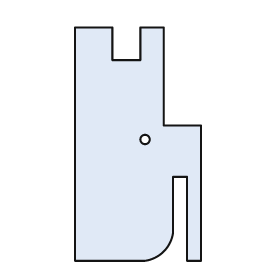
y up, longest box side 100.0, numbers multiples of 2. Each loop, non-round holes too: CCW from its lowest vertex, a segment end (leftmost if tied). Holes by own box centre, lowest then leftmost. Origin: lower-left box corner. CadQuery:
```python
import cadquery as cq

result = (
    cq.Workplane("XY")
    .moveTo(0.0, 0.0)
    .lineTo(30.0, 0.0)
    .threePointArc((38.0, 4.0), (42.0, 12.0))
    .lineTo(42.0, 36.0)
    .lineTo(48.0, 36.0)
    .lineTo(48.0, 0.0)
    .lineTo(54.0, 0.0)
    .lineTo(54.0, 58.0)
    .lineTo(38.0, 58.0)
    .lineTo(38.0, 100.0)
    .lineTo(28.0, 100.0)
    .lineTo(28.0, 86.0)
    .lineTo(16.0, 86.0)
    .lineTo(16.0, 100.0)
    .lineTo(0.0, 100.0)
    .close()
    .moveTo(30.0, 52.0)
    .circle(2.0)
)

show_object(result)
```